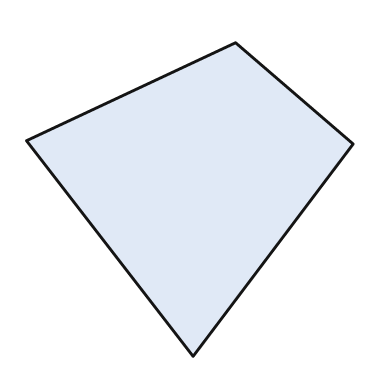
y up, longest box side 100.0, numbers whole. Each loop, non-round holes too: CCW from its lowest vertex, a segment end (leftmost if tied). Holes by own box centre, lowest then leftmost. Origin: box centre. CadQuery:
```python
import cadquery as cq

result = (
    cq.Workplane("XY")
    .moveTo(1.0, -48.0)
    .lineTo(50.0, 17.0)
    .lineTo(14.0, 48.0)
    .lineTo(-50.0, 18.0)
    .close()
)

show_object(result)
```